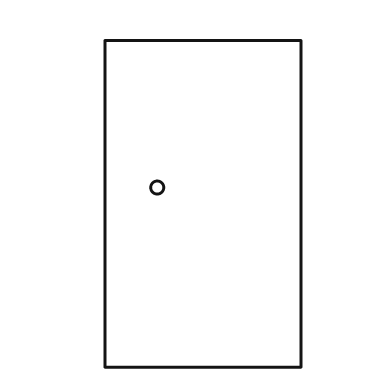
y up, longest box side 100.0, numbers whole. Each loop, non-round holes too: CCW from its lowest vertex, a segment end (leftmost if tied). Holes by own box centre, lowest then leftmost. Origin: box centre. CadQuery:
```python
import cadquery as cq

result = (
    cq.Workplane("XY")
    .moveTo(-30.0, -50.0)
    .lineTo(30.0, -50.0)
    .lineTo(30.0, 50.0)
    .lineTo(-30.0, 50.0)
    .close()
    .moveTo(-14.0, 5.0)
    .circle(2.0)
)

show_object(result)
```